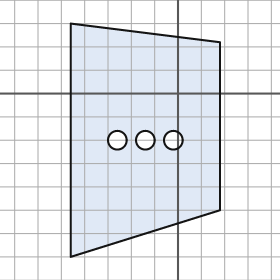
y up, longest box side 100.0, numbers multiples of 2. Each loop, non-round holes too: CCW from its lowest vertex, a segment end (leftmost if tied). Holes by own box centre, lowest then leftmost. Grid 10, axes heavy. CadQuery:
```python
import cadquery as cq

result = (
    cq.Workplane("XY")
    .moveTo(-46.0, -70.0)
    .lineTo(18.0, -50.0)
    .lineTo(18.0, 22.0)
    .lineTo(-46.0, 30.0)
    .close()
    .moveTo(-26.0, -20.0)
    .circle(4.0)
    .moveTo(-14.0, -20.0)
    .circle(4.0)
    .moveTo(-2.0, -20.0)
    .circle(4.0)
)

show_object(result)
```